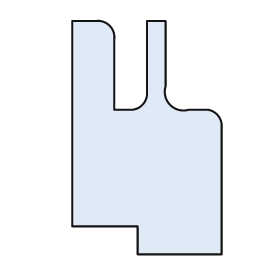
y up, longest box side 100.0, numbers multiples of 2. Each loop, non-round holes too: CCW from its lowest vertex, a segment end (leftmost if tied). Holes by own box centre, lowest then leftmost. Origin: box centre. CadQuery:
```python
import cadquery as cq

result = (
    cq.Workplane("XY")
    .moveTo(-4.0, -50.0)
    .lineTo(32.0, -50.0)
    .lineTo(32.0, 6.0)
    .threePointArc((30.0, 10.0), (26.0, 12.0))
    .lineTo(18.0, 12.0)
    .threePointArc((10.0, 14.0), (8.0, 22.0))
    .lineTo(8.0, 50.0)
    .lineTo(0.0, 50.0)
    .lineTo(0.0, 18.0)
    .threePointArc((-2.0, 14.0), (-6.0, 12.0))
    .lineTo(-14.0, 12.0)
    .lineTo(-14.0, 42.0)
    .threePointArc((-16.0, 48.0), (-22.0, 50.0))
    .lineTo(-32.0, 50.0)
    .lineTo(-32.0, -38.0)
    .lineTo(-4.0, -38.0)
    .close()
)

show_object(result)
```